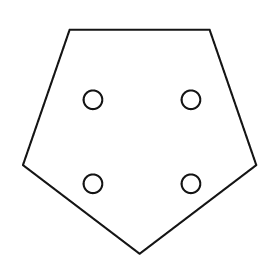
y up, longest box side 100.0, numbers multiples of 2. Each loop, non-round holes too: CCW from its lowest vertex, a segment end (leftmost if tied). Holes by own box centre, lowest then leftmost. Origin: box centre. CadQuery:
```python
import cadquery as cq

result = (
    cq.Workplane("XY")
    .moveTo(0.0, -48.0)
    .lineTo(50.0, -10.0)
    .lineTo(30.0, 48.0)
    .lineTo(-30.0, 48.0)
    .lineTo(-50.0, -10.0)
    .close()
    .moveTo(-20.0, -18.0)
    .circle(4.0)
    .moveTo(22.0, -18.0)
    .circle(4.0)
    .moveTo(-20.0, 18.0)
    .circle(4.0)
    .moveTo(22.0, 18.0)
    .circle(4.0)
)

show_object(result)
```